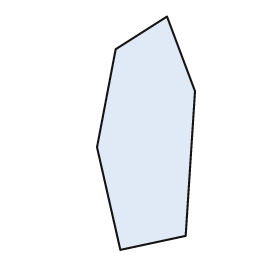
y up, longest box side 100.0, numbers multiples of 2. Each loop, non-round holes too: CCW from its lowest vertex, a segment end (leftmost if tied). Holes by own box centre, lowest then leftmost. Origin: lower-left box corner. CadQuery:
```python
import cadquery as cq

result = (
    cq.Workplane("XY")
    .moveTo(10.0, 0.0)
    .lineTo(38.0, 6.0)
    .lineTo(42.0, 68.0)
    .lineTo(30.0, 100.0)
    .lineTo(8.0, 86.0)
    .lineTo(0.0, 44.0)
    .close()
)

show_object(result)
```